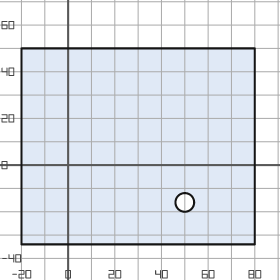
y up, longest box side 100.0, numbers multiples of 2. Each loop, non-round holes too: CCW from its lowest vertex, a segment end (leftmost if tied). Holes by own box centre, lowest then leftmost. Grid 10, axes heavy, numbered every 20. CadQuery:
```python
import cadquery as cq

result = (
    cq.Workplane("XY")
    .moveTo(-20.0, -34.0)
    .lineTo(80.0, -34.0)
    .lineTo(80.0, 50.0)
    .lineTo(-20.0, 50.0)
    .close()
    .moveTo(50.0, -16.0)
    .circle(4.0)
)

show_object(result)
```